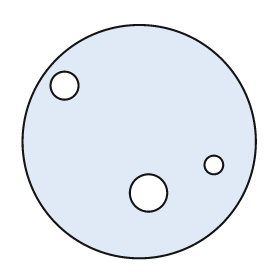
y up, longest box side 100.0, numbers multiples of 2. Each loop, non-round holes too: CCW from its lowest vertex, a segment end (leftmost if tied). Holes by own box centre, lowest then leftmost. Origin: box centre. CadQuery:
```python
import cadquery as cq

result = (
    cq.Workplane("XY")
    .moveTo(0.0, 0.0)
    .circle(50.0)
    .moveTo(4.0, -22.0)
    .circle(8.0)
    .moveTo(32.0, -10.0)
    .circle(4.0)
    .moveTo(-32.0, 24.0)
    .circle(6.0)
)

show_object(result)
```